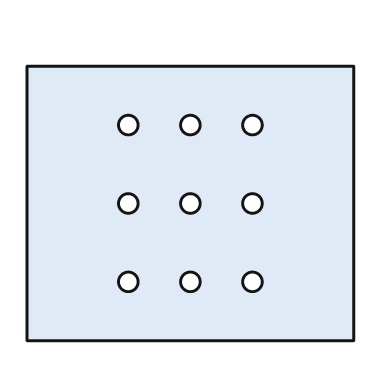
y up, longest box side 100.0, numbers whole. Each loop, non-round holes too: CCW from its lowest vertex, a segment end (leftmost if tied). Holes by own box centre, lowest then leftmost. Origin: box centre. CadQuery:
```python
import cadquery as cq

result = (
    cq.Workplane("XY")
    .moveTo(-50.0, -42.0)
    .lineTo(50.0, -42.0)
    .lineTo(50.0, 42.0)
    .lineTo(-50.0, 42.0)
    .close()
    .moveTo(-19.0, -24.0)
    .circle(3.0)
    .moveTo(0.0, -24.0)
    .circle(3.0)
    .moveTo(19.0, -24.0)
    .circle(3.0)
    .moveTo(-19.0, 0.0)
    .circle(3.0)
    .moveTo(0.0, 0.0)
    .circle(3.0)
    .moveTo(19.0, 0.0)
    .circle(3.0)
    .moveTo(-19.0, 24.0)
    .circle(3.0)
    .moveTo(0.0, 24.0)
    .circle(3.0)
    .moveTo(19.0, 24.0)
    .circle(3.0)
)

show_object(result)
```